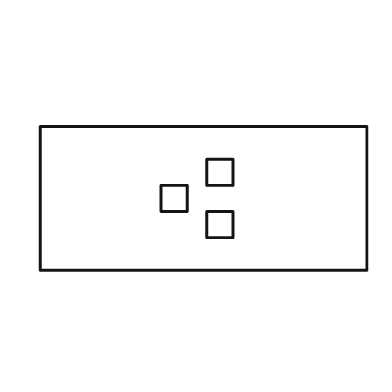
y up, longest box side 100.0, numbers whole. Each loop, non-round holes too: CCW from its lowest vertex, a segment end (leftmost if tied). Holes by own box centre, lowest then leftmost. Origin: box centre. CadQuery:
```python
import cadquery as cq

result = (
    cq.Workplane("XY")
    .moveTo(-50.0, -22.0)
    .lineTo(50.0, -22.0)
    .lineTo(50.0, 22.0)
    .lineTo(-50.0, 22.0)
    .close()
    .moveTo(1.0, -12.0)
    .lineTo(9.0, -12.0)
    .lineTo(9.0, -4.0)
    .lineTo(1.0, -4.0)
    .close()
    .moveTo(-13.0, -4.0)
    .lineTo(-5.0, -4.0)
    .lineTo(-5.0, 4.0)
    .lineTo(-13.0, 4.0)
    .close()
    .moveTo(1.0, 4.0)
    .lineTo(9.0, 4.0)
    .lineTo(9.0, 12.0)
    .lineTo(1.0, 12.0)
    .close()
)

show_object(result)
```